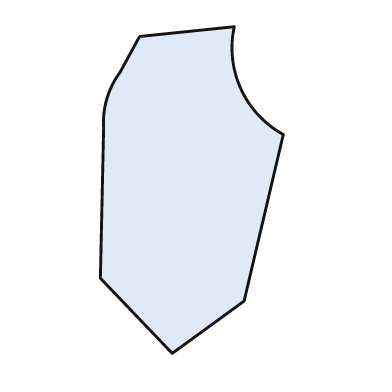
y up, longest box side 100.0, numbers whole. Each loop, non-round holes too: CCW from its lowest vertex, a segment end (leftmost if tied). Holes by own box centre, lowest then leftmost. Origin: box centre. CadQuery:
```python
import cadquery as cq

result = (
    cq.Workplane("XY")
    .moveTo(-6.0, -50.0)
    .lineTo(16.0, -34.0)
    .lineTo(28.0, 17.0)
    .threePointArc((15.0, 31.0), (13.0, 50.0))
    .lineTo(-16.0, 47.0)
    .lineTo(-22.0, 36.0)
    .threePointArc((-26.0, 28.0), (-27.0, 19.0))
    .lineTo(-28.0, -27.0)
    .close()
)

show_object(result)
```